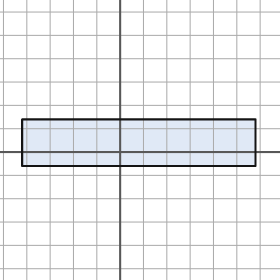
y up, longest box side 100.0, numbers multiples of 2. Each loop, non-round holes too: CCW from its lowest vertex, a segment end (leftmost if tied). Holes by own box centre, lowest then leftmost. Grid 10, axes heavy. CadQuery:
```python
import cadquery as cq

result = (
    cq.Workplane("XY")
    .moveTo(-42.0, -6.0)
    .lineTo(58.0, -6.0)
    .lineTo(58.0, 14.0)
    .lineTo(-42.0, 14.0)
    .close()
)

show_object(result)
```